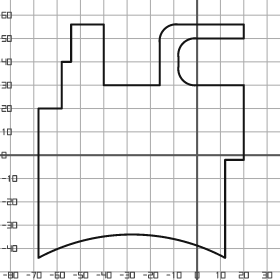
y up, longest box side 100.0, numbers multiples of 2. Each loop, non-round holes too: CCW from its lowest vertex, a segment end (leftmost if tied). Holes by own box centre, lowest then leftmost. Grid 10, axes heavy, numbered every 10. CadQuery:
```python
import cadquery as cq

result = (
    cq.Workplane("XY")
    .moveTo(-68.0, -44.0)
    .threePointArc((-28.0, -34.0), (12.0, -44.0))
    .lineTo(12.0, -2.0)
    .lineTo(20.0, -2.0)
    .lineTo(20.0, 30.0)
    .lineTo(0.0, 30.0)
    .threePointArc((-6.0, 32.0), (-8.0, 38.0))
    .lineTo(-8.0, 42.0)
    .threePointArc((-6.0, 48.0), (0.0, 50.0))
    .lineTo(20.0, 50.0)
    .lineTo(20.0, 56.0)
    .lineTo(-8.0, 56.0)
    .threePointArc((-14.0, 54.0), (-16.0, 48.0))
    .lineTo(-16.0, 30.0)
    .lineTo(-40.0, 30.0)
    .lineTo(-40.0, 56.0)
    .lineTo(-54.0, 56.0)
    .lineTo(-54.0, 40.0)
    .lineTo(-58.0, 40.0)
    .lineTo(-58.0, 20.0)
    .lineTo(-68.0, 20.0)
    .close()
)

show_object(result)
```